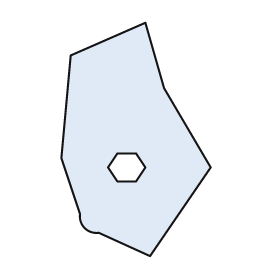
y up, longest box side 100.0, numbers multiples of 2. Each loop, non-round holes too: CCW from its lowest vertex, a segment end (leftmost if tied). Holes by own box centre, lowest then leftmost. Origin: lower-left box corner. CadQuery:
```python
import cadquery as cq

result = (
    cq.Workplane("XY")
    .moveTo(38.0, 0.0)
    .lineTo(64.0, 38.0)
    .lineTo(44.0, 72.0)
    .lineTo(36.0, 100.0)
    .lineTo(4.0, 86.0)
    .lineTo(0.0, 42.0)
    .lineTo(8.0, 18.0)
    .threePointArc((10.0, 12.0), (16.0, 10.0))
    .close()
    .moveTo(24.0, 32.0)
    .lineTo(32.0, 32.0)
    .lineTo(36.0, 38.0)
    .lineTo(32.0, 44.0)
    .lineTo(24.0, 44.0)
    .lineTo(20.0, 38.0)
    .close()
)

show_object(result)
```